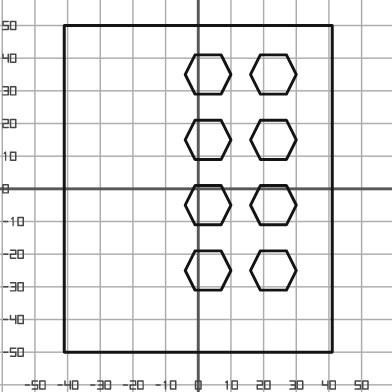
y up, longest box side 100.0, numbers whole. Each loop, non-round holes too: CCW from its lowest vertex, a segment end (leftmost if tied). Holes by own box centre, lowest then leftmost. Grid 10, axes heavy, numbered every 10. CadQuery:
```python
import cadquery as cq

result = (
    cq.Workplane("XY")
    .moveTo(-41.0, -50.0)
    .lineTo(41.0, -50.0)
    .lineTo(41.0, 50.0)
    .lineTo(-41.0, 50.0)
    .close()
    .moveTo(-1.0, -31.0)
    .lineTo(7.0, -31.0)
    .lineTo(10.0, -25.0)
    .lineTo(7.0, -19.0)
    .lineTo(-1.0, -19.0)
    .lineTo(-4.0, -25.0)
    .close()
    .moveTo(19.0, -31.0)
    .lineTo(27.0, -31.0)
    .lineTo(30.0, -25.0)
    .lineTo(27.0, -19.0)
    .lineTo(19.0, -19.0)
    .lineTo(16.0, -25.0)
    .close()
    .moveTo(-1.0, -11.0)
    .lineTo(7.0, -11.0)
    .lineTo(10.0, -5.0)
    .lineTo(7.0, 1.0)
    .lineTo(-1.0, 1.0)
    .lineTo(-4.0, -5.0)
    .close()
    .moveTo(19.0, -11.0)
    .lineTo(27.0, -11.0)
    .lineTo(30.0, -5.0)
    .lineTo(27.0, 1.0)
    .lineTo(19.0, 1.0)
    .lineTo(16.0, -5.0)
    .close()
    .moveTo(-1.0, 9.0)
    .lineTo(7.0, 9.0)
    .lineTo(10.0, 15.0)
    .lineTo(7.0, 21.0)
    .lineTo(-1.0, 21.0)
    .lineTo(-4.0, 15.0)
    .close()
    .moveTo(19.0, 9.0)
    .lineTo(27.0, 9.0)
    .lineTo(30.0, 15.0)
    .lineTo(27.0, 21.0)
    .lineTo(19.0, 21.0)
    .lineTo(16.0, 15.0)
    .close()
    .moveTo(-1.0, 29.0)
    .lineTo(7.0, 29.0)
    .lineTo(10.0, 35.0)
    .lineTo(7.0, 41.0)
    .lineTo(-1.0, 41.0)
    .lineTo(-4.0, 35.0)
    .close()
    .moveTo(19.0, 29.0)
    .lineTo(27.0, 29.0)
    .lineTo(30.0, 35.0)
    .lineTo(27.0, 41.0)
    .lineTo(19.0, 41.0)
    .lineTo(16.0, 35.0)
    .close()
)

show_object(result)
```